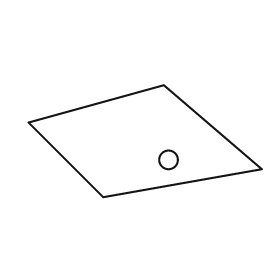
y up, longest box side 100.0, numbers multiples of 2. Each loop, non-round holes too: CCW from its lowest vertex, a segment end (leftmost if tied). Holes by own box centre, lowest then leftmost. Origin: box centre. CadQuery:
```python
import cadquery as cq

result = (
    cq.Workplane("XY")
    .moveTo(-18.0, -24.0)
    .lineTo(50.0, -12.0)
    .lineTo(8.0, 24.0)
    .lineTo(-50.0, 8.0)
    .close()
    .moveTo(10.0, -8.0)
    .circle(4.0)
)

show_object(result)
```